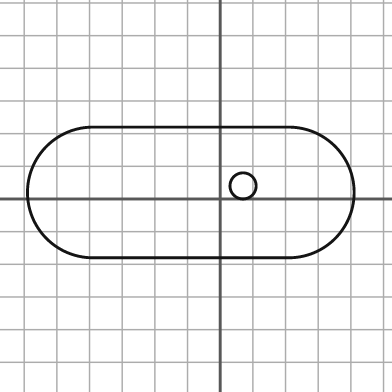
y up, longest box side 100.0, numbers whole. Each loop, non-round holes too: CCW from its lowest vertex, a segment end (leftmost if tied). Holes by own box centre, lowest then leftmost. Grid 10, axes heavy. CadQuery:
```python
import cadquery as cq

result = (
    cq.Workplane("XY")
    .moveTo(-39.0, -18.0)
    .lineTo(21.0, -18.0)
    .threePointArc((41.0, 2.0), (21.0, 22.0))
    .lineTo(-39.0, 22.0)
    .threePointArc((-59.0, 2.0), (-39.0, -18.0))
    .close()
    .moveTo(7.0, 4.0)
    .circle(4.0)
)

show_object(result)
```